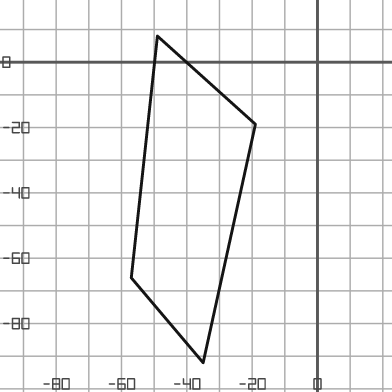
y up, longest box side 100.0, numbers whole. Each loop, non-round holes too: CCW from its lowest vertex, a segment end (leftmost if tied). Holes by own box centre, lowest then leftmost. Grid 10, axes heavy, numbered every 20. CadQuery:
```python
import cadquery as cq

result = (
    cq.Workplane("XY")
    .moveTo(-35.0, -92.0)
    .lineTo(-19.0, -19.0)
    .lineTo(-49.0, 8.0)
    .lineTo(-57.0, -66.0)
    .close()
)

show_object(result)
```